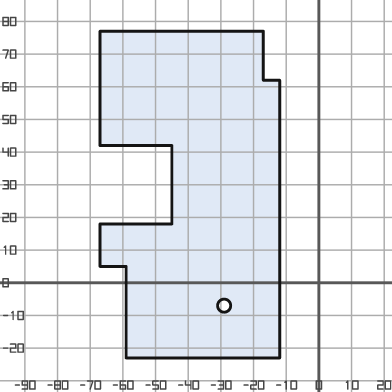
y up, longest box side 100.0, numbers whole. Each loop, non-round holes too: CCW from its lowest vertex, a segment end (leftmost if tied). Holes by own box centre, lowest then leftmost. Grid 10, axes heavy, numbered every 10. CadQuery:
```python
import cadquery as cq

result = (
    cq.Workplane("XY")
    .moveTo(-59.0, -23.0)
    .lineTo(-12.0, -23.0)
    .lineTo(-12.0, 62.0)
    .lineTo(-17.0, 62.0)
    .lineTo(-17.0, 77.0)
    .lineTo(-67.0, 77.0)
    .lineTo(-67.0, 42.0)
    .lineTo(-45.0, 42.0)
    .lineTo(-45.0, 18.0)
    .lineTo(-67.0, 18.0)
    .lineTo(-67.0, 5.0)
    .lineTo(-59.0, 5.0)
    .close()
    .moveTo(-29.0, -7.0)
    .circle(2.0)
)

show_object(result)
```